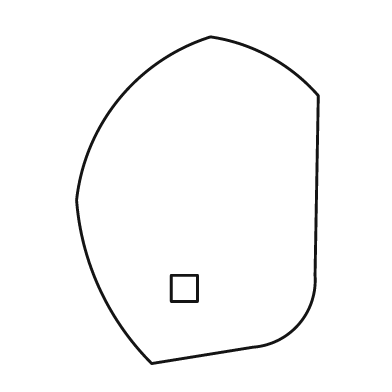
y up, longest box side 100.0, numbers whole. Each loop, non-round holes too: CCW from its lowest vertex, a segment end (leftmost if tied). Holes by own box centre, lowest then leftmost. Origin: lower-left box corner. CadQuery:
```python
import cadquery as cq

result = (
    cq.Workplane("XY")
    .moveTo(23.0, 0.0)
    .lineTo(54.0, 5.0)
    .threePointArc((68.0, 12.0), (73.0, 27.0))
    .lineTo(74.0, 82.0)
    .threePointArc((59.0, 94.0), (41.0, 100.0))
    .threePointArc((13.0, 81.0), (0.0, 50.0))
    .threePointArc((7.0, 23.0), (23.0, 0.0))
    .close()
    .moveTo(29.0, 19.0)
    .lineTo(37.0, 19.0)
    .lineTo(37.0, 27.0)
    .lineTo(29.0, 27.0)
    .close()
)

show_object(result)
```